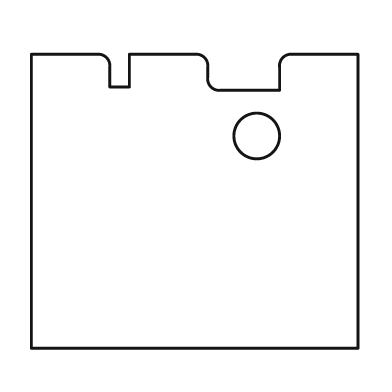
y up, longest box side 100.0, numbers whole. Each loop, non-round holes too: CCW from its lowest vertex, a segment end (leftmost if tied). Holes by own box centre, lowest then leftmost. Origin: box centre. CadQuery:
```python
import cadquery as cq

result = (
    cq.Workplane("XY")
    .moveTo(-50.0, -45.0)
    .lineTo(50.0, -45.0)
    .lineTo(50.0, 45.0)
    .lineTo(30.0, 45.0)
    .threePointArc((27.0, 44.0), (26.0, 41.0))
    .lineTo(26.0, 34.0)
    .lineTo(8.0, 34.0)
    .threePointArc((5.0, 35.0), (4.0, 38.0))
    .lineTo(4.0, 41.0)
    .threePointArc((3.0, 44.0), (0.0, 45.0))
    .lineTo(-20.0, 45.0)
    .lineTo(-20.0, 35.0)
    .lineTo(-26.0, 35.0)
    .lineTo(-26.0, 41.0)
    .threePointArc((-27.0, 44.0), (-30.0, 45.0))
    .lineTo(-50.0, 45.0)
    .close()
    .moveTo(19.0, 20.0)
    .circle(7.0)
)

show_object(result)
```